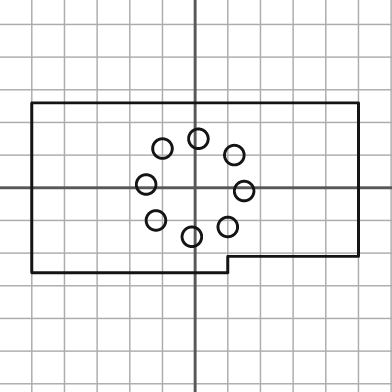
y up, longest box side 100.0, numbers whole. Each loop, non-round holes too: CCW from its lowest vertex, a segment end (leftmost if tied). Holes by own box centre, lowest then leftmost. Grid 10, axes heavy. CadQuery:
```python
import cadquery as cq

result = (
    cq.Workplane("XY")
    .moveTo(-50.0, -26.0)
    .lineTo(10.0, -26.0)
    .lineTo(10.0, -21.0)
    .lineTo(50.0, -21.0)
    .lineTo(50.0, 26.0)
    .lineTo(-50.0, 26.0)
    .close()
    .moveTo(-1.0, -15.0)
    .circle(3.0)
    .moveTo(10.0, -12.0)
    .circle(3.0)
    .moveTo(-12.0, -10.0)
    .circle(3.0)
    .moveTo(15.0, -1.0)
    .circle(3.0)
    .moveTo(-15.0, 1.0)
    .circle(3.0)
    .moveTo(12.0, 10.0)
    .circle(3.0)
    .moveTo(-10.0, 12.0)
    .circle(3.0)
    .moveTo(1.0, 15.0)
    .circle(3.0)
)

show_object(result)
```